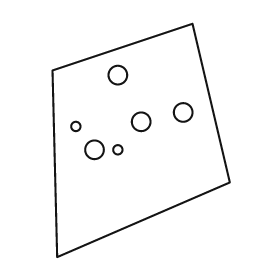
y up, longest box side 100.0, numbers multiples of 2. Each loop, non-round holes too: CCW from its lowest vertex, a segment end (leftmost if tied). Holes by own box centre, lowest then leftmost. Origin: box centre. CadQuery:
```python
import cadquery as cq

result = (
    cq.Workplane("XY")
    .moveTo(-36.0, -50.0)
    .lineTo(38.0, -18.0)
    .lineTo(22.0, 50.0)
    .lineTo(-38.0, 30.0)
    .close()
    .moveTo(-20.0, -4.0)
    .circle(4.0)
    .moveTo(-10.0, -4.0)
    .circle(2.0)
    .moveTo(-28.0, 6.0)
    .circle(2.0)
    .moveTo(0.0, 8.0)
    .circle(4.0)
    .moveTo(18.0, 12.0)
    .circle(4.0)
    .moveTo(-10.0, 28.0)
    .circle(4.0)
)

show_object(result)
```